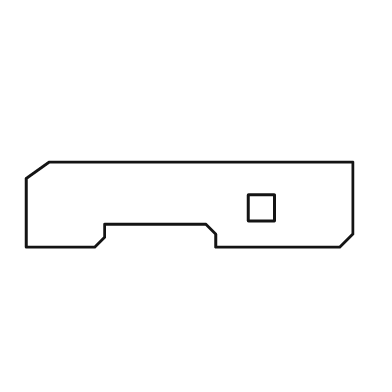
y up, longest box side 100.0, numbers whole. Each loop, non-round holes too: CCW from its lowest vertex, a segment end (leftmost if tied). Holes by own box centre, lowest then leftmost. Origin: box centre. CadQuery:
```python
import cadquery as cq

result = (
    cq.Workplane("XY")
    .moveTo(-50.0, -13.0)
    .lineTo(-29.0, -13.0)
    .lineTo(-26.0, -10.0)
    .lineTo(-26.0, -6.0)
    .lineTo(5.0, -6.0)
    .lineTo(8.0, -9.0)
    .lineTo(8.0, -13.0)
    .lineTo(46.0, -13.0)
    .lineTo(50.0, -9.0)
    .lineTo(50.0, 13.0)
    .lineTo(-43.0, 13.0)
    .lineTo(-50.0, 8.0)
    .close()
    .moveTo(18.0, -5.0)
    .lineTo(26.0, -5.0)
    .lineTo(26.0, 3.0)
    .lineTo(18.0, 3.0)
    .close()
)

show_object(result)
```